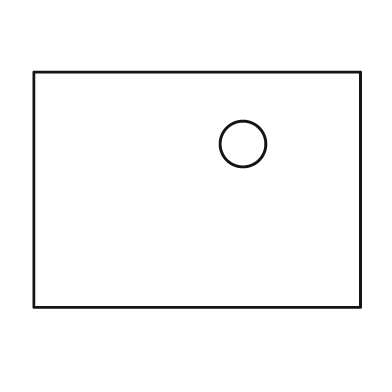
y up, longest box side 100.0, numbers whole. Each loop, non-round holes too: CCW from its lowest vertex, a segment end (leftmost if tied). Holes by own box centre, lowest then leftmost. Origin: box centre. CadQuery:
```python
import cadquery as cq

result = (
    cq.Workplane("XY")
    .moveTo(-50.0, -36.0)
    .lineTo(50.0, -36.0)
    .lineTo(50.0, 36.0)
    .lineTo(-50.0, 36.0)
    .close()
    .moveTo(14.0, 14.0)
    .circle(7.0)
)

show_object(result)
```